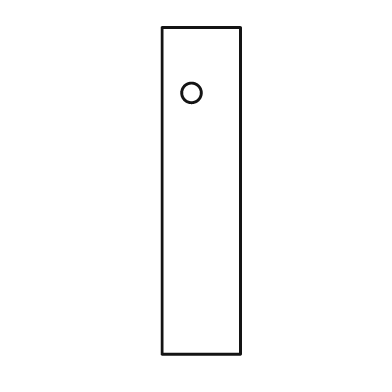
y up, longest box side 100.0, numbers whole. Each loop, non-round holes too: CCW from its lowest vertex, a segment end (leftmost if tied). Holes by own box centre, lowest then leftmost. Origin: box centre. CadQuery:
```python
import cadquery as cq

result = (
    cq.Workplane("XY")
    .moveTo(-12.0, -50.0)
    .lineTo(12.0, -50.0)
    .lineTo(12.0, 50.0)
    .lineTo(-12.0, 50.0)
    .close()
    .moveTo(-3.0, 30.0)
    .circle(3.0)
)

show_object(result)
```